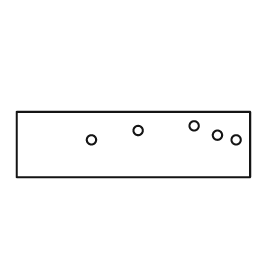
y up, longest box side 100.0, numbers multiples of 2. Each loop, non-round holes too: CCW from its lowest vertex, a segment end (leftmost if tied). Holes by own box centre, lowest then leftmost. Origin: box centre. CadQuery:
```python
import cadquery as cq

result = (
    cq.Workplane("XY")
    .moveTo(-50.0, -14.0)
    .lineTo(50.0, -14.0)
    .lineTo(50.0, 14.0)
    .lineTo(-50.0, 14.0)
    .close()
    .moveTo(-18.0, 2.0)
    .circle(2.0)
    .moveTo(44.0, 2.0)
    .circle(2.0)
    .moveTo(36.0, 4.0)
    .circle(2.0)
    .moveTo(2.0, 6.0)
    .circle(2.0)
    .moveTo(26.0, 8.0)
    .circle(2.0)
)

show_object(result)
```